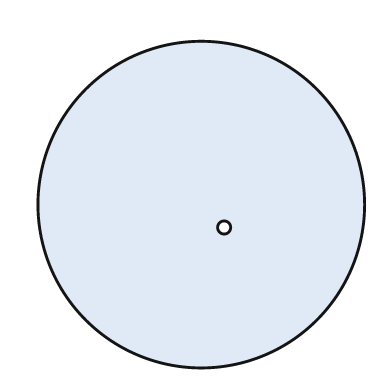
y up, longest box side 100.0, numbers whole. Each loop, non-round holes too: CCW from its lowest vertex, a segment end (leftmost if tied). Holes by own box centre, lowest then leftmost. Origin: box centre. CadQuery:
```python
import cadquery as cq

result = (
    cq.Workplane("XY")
    .moveTo(0.0, 0.0)
    .circle(50.0)
    .moveTo(7.0, -7.0)
    .circle(2.0)
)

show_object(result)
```